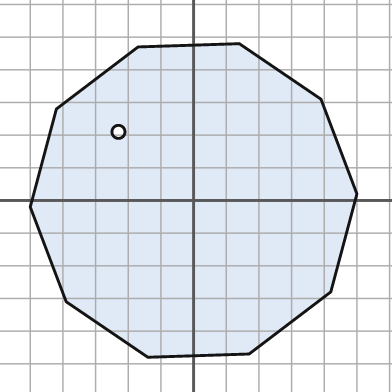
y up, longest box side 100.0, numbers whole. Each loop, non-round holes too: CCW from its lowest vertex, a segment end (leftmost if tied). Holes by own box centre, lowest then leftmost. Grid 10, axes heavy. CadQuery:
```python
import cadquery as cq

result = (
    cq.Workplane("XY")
    .moveTo(-14.0, -48.0)
    .lineTo(17.0, -47.0)
    .lineTo(42.0, -28.0)
    .lineTo(50.0, 2.0)
    .lineTo(39.0, 31.0)
    .lineTo(14.0, 48.0)
    .lineTo(-17.0, 47.0)
    .lineTo(-42.0, 28.0)
    .lineTo(-50.0, -2.0)
    .lineTo(-39.0, -31.0)
    .close()
    .moveTo(-23.0, 21.0)
    .circle(2.0)
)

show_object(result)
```